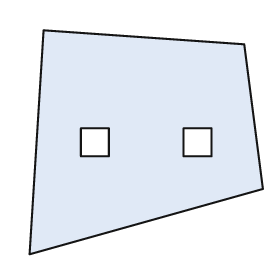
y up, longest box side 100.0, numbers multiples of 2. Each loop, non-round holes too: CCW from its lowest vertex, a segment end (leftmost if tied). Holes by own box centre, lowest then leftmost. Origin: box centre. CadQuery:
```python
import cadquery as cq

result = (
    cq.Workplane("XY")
    .moveTo(-50.0, -48.0)
    .lineTo(50.0, -20.0)
    .lineTo(42.0, 42.0)
    .lineTo(-44.0, 48.0)
    .close()
    .moveTo(-28.0, -6.0)
    .lineTo(-16.0, -6.0)
    .lineTo(-16.0, 6.0)
    .lineTo(-28.0, 6.0)
    .close()
    .moveTo(16.0, -6.0)
    .lineTo(28.0, -6.0)
    .lineTo(28.0, 6.0)
    .lineTo(16.0, 6.0)
    .close()
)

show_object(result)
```